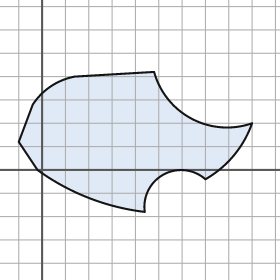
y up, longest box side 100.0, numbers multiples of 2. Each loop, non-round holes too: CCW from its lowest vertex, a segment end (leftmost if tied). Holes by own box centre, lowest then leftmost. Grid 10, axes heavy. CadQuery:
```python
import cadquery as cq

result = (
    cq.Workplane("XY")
    .moveTo(44.0, -18.0)
    .threePointArc((52.0, -2.0), (70.0, -4.0))
    .threePointArc((82.0, 6.0), (90.0, 20.0))
    .threePointArc((64.0, 22.0), (48.0, 42.0))
    .lineTo(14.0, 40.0)
    .threePointArc((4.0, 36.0), (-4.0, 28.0))
    .lineTo(-10.0, 12.0)
    .lineTo(-2.0, 0.0)
    .threePointArc((20.0, -12.0), (44.0, -18.0))
    .close()
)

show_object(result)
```